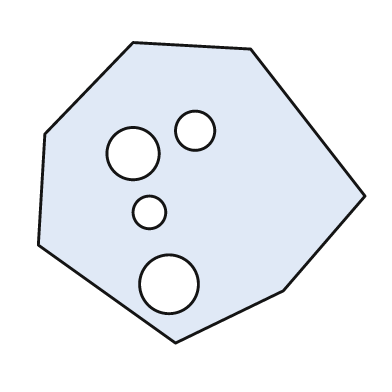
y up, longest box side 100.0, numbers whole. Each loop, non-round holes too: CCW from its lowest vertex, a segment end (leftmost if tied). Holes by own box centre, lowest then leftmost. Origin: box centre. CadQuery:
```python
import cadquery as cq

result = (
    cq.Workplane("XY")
    .moveTo(-8.0, -46.0)
    .lineTo(25.0, -30.0)
    .lineTo(50.0, -1.0)
    .lineTo(15.0, 44.0)
    .lineTo(-21.0, 46.0)
    .lineTo(-48.0, 18.0)
    .lineTo(-50.0, -16.0)
    .close()
    .moveTo(-10.0, -28.0)
    .circle(9.0)
    .moveTo(-16.0, -6.0)
    .circle(5.0)
    .moveTo(-21.0, 12.0)
    .circle(8.0)
    .moveTo(-2.0, 19.0)
    .circle(6.0)
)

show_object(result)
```